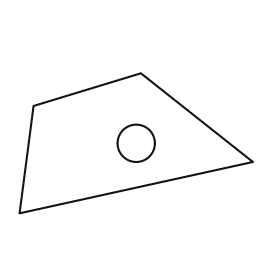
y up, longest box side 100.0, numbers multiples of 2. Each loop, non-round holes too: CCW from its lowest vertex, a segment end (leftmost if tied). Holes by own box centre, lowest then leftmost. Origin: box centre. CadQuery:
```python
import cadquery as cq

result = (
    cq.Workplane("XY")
    .moveTo(-50.0, -30.0)
    .lineTo(50.0, -8.0)
    .lineTo(2.0, 30.0)
    .lineTo(-44.0, 16.0)
    .close()
    .moveTo(0.0, 0.0)
    .circle(8.0)
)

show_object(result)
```